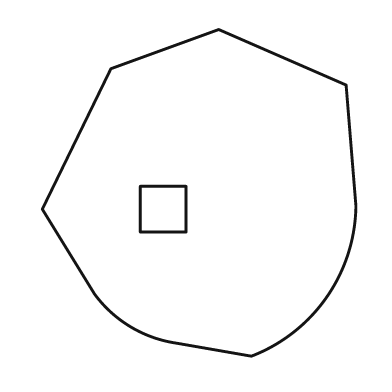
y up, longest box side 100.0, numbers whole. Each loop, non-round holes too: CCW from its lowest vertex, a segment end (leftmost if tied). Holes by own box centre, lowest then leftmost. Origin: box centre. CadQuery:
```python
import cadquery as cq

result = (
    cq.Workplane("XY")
    .moveTo(16.0, -50.0)
    .threePointArc((39.0, -32.0), (48.0, -4.0))
    .lineTo(45.0, 33.0)
    .lineTo(6.0, 50.0)
    .lineTo(-27.0, 38.0)
    .lineTo(-48.0, -5.0)
    .lineTo(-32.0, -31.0)
    .threePointArc((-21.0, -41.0), (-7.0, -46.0))
    .close()
    .moveTo(-18.0, -12.0)
    .lineTo(-4.0, -12.0)
    .lineTo(-4.0, 2.0)
    .lineTo(-18.0, 2.0)
    .close()
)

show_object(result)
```